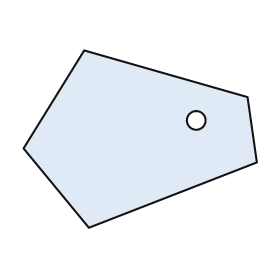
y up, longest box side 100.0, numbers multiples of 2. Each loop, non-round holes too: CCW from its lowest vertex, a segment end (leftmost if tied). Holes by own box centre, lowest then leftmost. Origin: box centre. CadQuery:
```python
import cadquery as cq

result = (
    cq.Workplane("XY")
    .moveTo(-22.0, -38.0)
    .lineTo(50.0, -10.0)
    .lineTo(46.0, 18.0)
    .lineTo(-24.0, 38.0)
    .lineTo(-50.0, -4.0)
    .close()
    .moveTo(24.0, 8.0)
    .circle(4.0)
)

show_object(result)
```